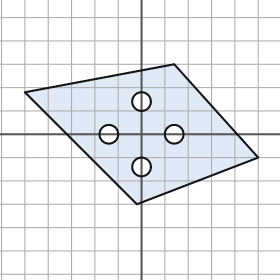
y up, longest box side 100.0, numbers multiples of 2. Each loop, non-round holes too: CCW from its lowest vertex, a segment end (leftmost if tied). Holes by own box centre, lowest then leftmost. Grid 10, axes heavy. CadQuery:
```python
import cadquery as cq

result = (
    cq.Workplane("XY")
    .moveTo(-2.0, -30.0)
    .lineTo(50.0, -10.0)
    .lineTo(14.0, 30.0)
    .lineTo(-50.0, 18.0)
    .close()
    .moveTo(0.0, -14.0)
    .circle(4.0)
    .moveTo(-14.0, 0.0)
    .circle(4.0)
    .moveTo(14.0, 0.0)
    .circle(4.0)
    .moveTo(0.0, 14.0)
    .circle(4.0)
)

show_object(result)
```